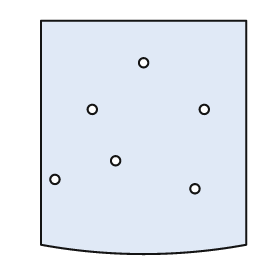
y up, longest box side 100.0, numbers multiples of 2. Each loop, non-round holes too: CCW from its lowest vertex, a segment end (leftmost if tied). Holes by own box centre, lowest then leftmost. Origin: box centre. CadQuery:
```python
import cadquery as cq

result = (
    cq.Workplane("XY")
    .moveTo(-44.0, -46.0)
    .threePointArc((0.0, -50.0), (44.0, -46.0))
    .lineTo(44.0, 50.0)
    .lineTo(-44.0, 50.0)
    .close()
    .moveTo(22.0, -22.0)
    .circle(2.0)
    .moveTo(-38.0, -18.0)
    .circle(2.0)
    .moveTo(-12.0, -10.0)
    .circle(2.0)
    .moveTo(-22.0, 12.0)
    .circle(2.0)
    .moveTo(26.0, 12.0)
    .circle(2.0)
    .moveTo(0.0, 32.0)
    .circle(2.0)
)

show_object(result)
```